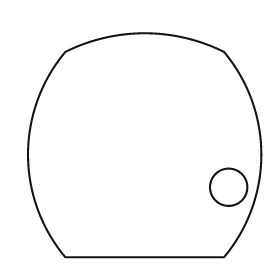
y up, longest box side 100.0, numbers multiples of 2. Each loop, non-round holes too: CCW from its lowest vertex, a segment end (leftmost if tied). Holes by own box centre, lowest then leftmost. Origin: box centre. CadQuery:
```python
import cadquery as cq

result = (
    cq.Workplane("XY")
    .moveTo(-34.0, -48.0)
    .lineTo(34.0, -48.0)
    .threePointArc((50.0, -4.0), (34.0, 40.0))
    .threePointArc((0.0, 48.0), (-34.0, 40.0))
    .threePointArc((-50.0, -4.0), (-34.0, -48.0))
    .close()
    .moveTo(36.0, -18.0)
    .circle(8.0)
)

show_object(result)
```